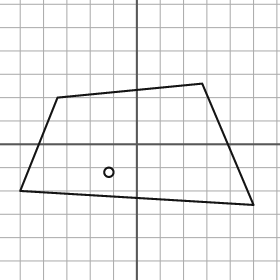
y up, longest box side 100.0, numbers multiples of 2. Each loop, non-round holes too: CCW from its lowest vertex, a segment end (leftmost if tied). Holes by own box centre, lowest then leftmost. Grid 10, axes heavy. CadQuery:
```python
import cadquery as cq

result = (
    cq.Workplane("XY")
    .moveTo(50.0, -26.0)
    .lineTo(28.0, 26.0)
    .lineTo(-34.0, 20.0)
    .lineTo(-50.0, -20.0)
    .close()
    .moveTo(-12.0, -12.0)
    .circle(2.0)
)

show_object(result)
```